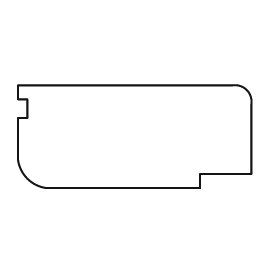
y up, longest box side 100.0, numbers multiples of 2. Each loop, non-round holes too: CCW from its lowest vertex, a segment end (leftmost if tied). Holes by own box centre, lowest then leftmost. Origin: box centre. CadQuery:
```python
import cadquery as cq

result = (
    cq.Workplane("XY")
    .moveTo(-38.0, -22.0)
    .lineTo(28.0, -22.0)
    .lineTo(28.0, -16.0)
    .lineTo(50.0, -16.0)
    .lineTo(50.0, 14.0)
    .threePointArc((48.0, 20.0), (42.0, 22.0))
    .lineTo(-50.0, 22.0)
    .lineTo(-50.0, 16.0)
    .lineTo(-46.0, 16.0)
    .lineTo(-46.0, 8.0)
    .lineTo(-50.0, 8.0)
    .lineTo(-50.0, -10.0)
    .threePointArc((-46.0, -18.0), (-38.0, -22.0))
    .close()
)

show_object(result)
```